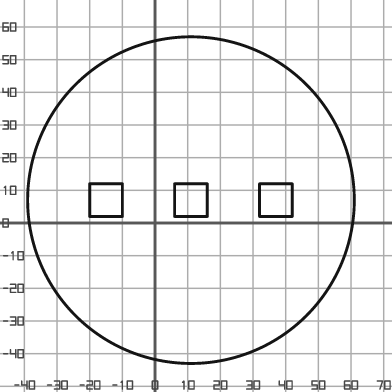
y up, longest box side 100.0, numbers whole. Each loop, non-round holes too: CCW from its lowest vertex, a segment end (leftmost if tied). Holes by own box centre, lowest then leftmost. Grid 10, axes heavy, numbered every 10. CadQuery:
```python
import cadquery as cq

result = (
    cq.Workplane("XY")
    .moveTo(11.0, 7.0)
    .circle(50.0)
    .moveTo(-20.0, 2.0)
    .lineTo(-10.0, 2.0)
    .lineTo(-10.0, 12.0)
    .lineTo(-20.0, 12.0)
    .close()
    .moveTo(6.0, 2.0)
    .lineTo(16.0, 2.0)
    .lineTo(16.0, 12.0)
    .lineTo(6.0, 12.0)
    .close()
    .moveTo(32.0, 2.0)
    .lineTo(42.0, 2.0)
    .lineTo(42.0, 12.0)
    .lineTo(32.0, 12.0)
    .close()
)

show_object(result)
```